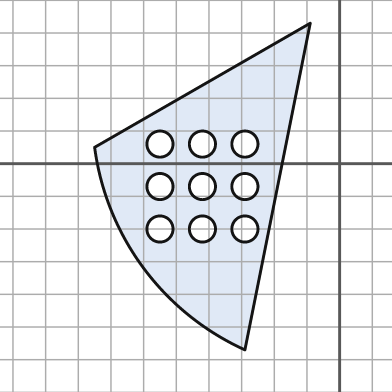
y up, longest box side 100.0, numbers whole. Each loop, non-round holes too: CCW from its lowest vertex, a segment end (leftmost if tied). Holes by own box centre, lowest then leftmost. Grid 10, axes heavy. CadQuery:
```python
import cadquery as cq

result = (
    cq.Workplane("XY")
    .moveTo(-29.0, -57.0)
    .lineTo(-9.0, 43.0)
    .lineTo(-75.0, 5.0)
    .threePointArc((-60.0, -32.0), (-29.0, -57.0))
    .close()
    .moveTo(-55.0, -20.0)
    .circle(4.0)
    .moveTo(-42.0, -20.0)
    .circle(4.0)
    .moveTo(-29.0, -20.0)
    .circle(4.0)
    .moveTo(-55.0, -7.0)
    .circle(4.0)
    .moveTo(-42.0, -7.0)
    .circle(4.0)
    .moveTo(-29.0, -7.0)
    .circle(4.0)
    .moveTo(-55.0, 6.0)
    .circle(4.0)
    .moveTo(-42.0, 6.0)
    .circle(4.0)
    .moveTo(-29.0, 6.0)
    .circle(4.0)
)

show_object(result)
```